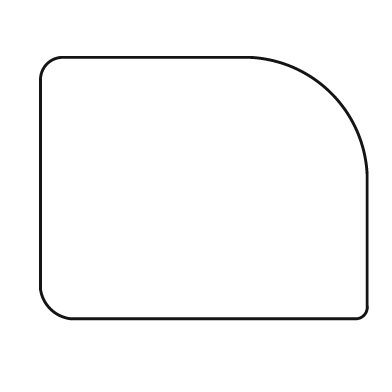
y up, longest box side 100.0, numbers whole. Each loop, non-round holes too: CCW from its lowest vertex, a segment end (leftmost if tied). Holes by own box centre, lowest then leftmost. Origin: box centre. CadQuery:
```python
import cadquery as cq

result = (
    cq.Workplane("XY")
    .moveTo(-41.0, -40.0)
    .lineTo(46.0, -40.0)
    .threePointArc((49.0, -39.0), (50.0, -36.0))
    .lineTo(50.0, 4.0)
    .threePointArc((39.0, 29.0), (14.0, 40.0))
    .lineTo(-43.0, 40.0)
    .threePointArc((-48.0, 38.0), (-50.0, 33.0))
    .lineTo(-50.0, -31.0)
    .threePointArc((-47.0, -37.0), (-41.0, -40.0))
    .close()
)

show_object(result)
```